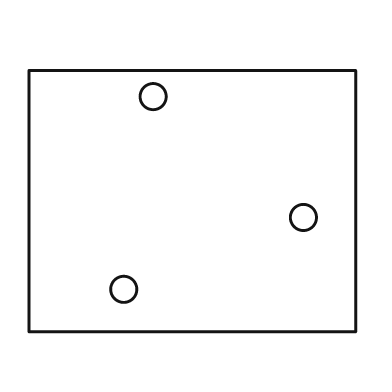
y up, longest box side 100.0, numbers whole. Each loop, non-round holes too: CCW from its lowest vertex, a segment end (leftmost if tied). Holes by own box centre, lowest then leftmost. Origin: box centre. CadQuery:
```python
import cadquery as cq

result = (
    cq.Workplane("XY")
    .moveTo(-50.0, -40.0)
    .lineTo(50.0, -40.0)
    .lineTo(50.0, 40.0)
    .lineTo(-50.0, 40.0)
    .close()
    .moveTo(-21.0, -27.0)
    .circle(4.0)
    .moveTo(34.0, -5.0)
    .circle(4.0)
    .moveTo(-12.0, 32.0)
    .circle(4.0)
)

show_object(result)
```